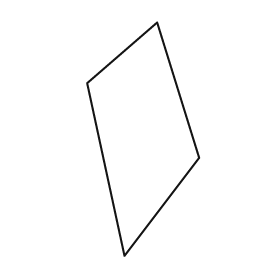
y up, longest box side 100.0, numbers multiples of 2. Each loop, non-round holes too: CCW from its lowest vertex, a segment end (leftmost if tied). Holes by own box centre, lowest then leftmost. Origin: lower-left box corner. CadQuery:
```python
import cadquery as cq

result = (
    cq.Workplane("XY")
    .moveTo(16.0, 0.0)
    .lineTo(48.0, 42.0)
    .lineTo(30.0, 100.0)
    .lineTo(0.0, 74.0)
    .close()
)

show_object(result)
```